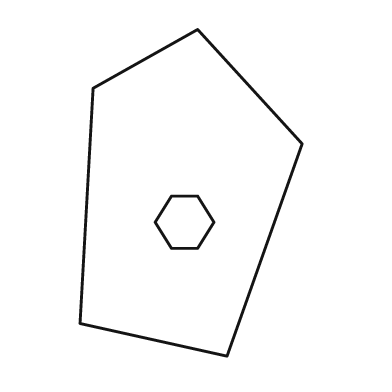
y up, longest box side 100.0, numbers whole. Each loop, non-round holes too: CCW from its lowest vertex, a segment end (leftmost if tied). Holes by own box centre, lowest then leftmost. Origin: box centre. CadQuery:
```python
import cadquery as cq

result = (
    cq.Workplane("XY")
    .moveTo(11.0, -50.0)
    .lineTo(34.0, 15.0)
    .lineTo(2.0, 50.0)
    .lineTo(-30.0, 32.0)
    .lineTo(-34.0, -40.0)
    .close()
    .moveTo(-6.0, -17.0)
    .lineTo(2.0, -17.0)
    .lineTo(7.0, -9.0)
    .lineTo(2.0, -1.0)
    .lineTo(-6.0, -1.0)
    .lineTo(-11.0, -9.0)
    .close()
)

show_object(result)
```